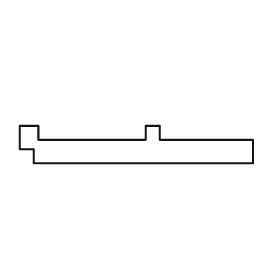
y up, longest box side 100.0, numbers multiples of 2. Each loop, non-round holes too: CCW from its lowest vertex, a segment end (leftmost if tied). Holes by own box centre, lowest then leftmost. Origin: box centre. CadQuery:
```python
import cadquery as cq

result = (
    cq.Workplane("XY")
    .moveTo(-44.0, -8.0)
    .lineTo(50.0, -8.0)
    .lineTo(50.0, 2.0)
    .lineTo(10.0, 2.0)
    .lineTo(10.0, 8.0)
    .lineTo(4.0, 8.0)
    .lineTo(4.0, 2.0)
    .lineTo(-42.0, 2.0)
    .lineTo(-42.0, 8.0)
    .lineTo(-50.0, 8.0)
    .lineTo(-50.0, -2.0)
    .lineTo(-44.0, -2.0)
    .close()
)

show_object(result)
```